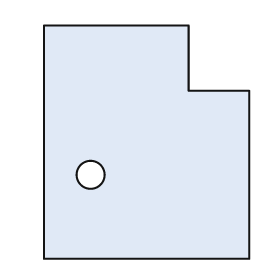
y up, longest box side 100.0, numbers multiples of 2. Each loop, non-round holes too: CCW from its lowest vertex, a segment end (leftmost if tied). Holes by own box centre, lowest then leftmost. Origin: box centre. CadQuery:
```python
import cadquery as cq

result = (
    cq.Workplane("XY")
    .moveTo(-44.0, -50.0)
    .lineTo(44.0, -50.0)
    .lineTo(44.0, 22.0)
    .lineTo(18.0, 22.0)
    .lineTo(18.0, 50.0)
    .lineTo(-44.0, 50.0)
    .close()
    .moveTo(-24.0, -14.0)
    .circle(6.0)
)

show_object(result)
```